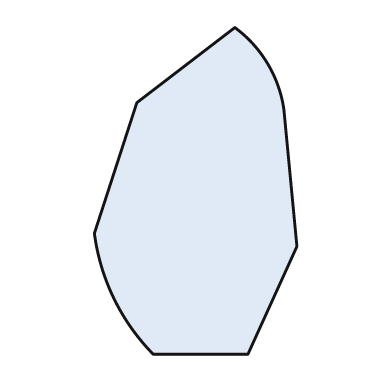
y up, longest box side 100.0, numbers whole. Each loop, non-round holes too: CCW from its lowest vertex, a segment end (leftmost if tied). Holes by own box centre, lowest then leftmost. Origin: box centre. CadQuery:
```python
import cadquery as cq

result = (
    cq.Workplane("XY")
    .moveTo(-13.0, -50.0)
    .lineTo(16.0, -50.0)
    .lineTo(31.0, -17.0)
    .lineTo(27.0, 25.0)
    .threePointArc((22.0, 39.0), (12.0, 50.0))
    .lineTo(-18.0, 27.0)
    .lineTo(-31.0, -13.0)
    .threePointArc((-25.0, -33.0), (-13.0, -50.0))
    .close()
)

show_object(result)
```